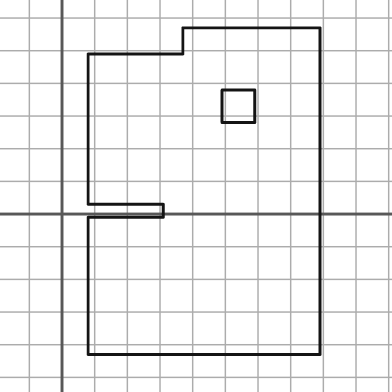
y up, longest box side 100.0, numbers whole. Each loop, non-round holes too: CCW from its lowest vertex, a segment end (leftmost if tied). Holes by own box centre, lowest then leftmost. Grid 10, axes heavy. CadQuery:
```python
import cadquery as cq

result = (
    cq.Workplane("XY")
    .moveTo(8.0, -43.0)
    .lineTo(79.0, -43.0)
    .lineTo(79.0, 57.0)
    .lineTo(37.0, 57.0)
    .lineTo(37.0, 49.0)
    .lineTo(8.0, 49.0)
    .lineTo(8.0, 3.0)
    .lineTo(31.0, 3.0)
    .lineTo(31.0, -1.0)
    .lineTo(8.0, -1.0)
    .close()
    .moveTo(49.0, 28.0)
    .lineTo(59.0, 28.0)
    .lineTo(59.0, 38.0)
    .lineTo(49.0, 38.0)
    .close()
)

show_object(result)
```